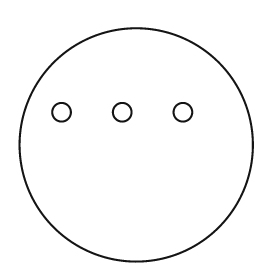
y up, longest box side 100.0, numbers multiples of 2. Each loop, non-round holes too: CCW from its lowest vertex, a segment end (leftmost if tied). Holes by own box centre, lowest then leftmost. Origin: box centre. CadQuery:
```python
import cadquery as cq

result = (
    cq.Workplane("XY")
    .moveTo(0.0, 0.0)
    .circle(50.0)
    .moveTo(-32.0, 14.0)
    .circle(4.0)
    .moveTo(-6.0, 14.0)
    .circle(4.0)
    .moveTo(20.0, 14.0)
    .circle(4.0)
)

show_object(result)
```